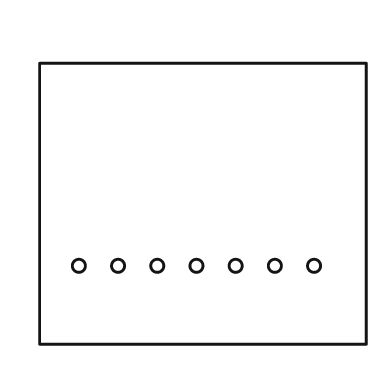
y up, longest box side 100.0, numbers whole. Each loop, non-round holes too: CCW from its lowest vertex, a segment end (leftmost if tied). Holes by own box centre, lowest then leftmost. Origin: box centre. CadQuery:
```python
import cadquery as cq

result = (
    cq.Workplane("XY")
    .moveTo(-50.0, -43.0)
    .lineTo(50.0, -43.0)
    .lineTo(50.0, 43.0)
    .lineTo(-50.0, 43.0)
    .close()
    .moveTo(-38.0, -19.0)
    .circle(2.0)
    .moveTo(-26.0, -19.0)
    .circle(2.0)
    .moveTo(-14.0, -19.0)
    .circle(2.0)
    .moveTo(-2.0, -19.0)
    .circle(2.0)
    .moveTo(10.0, -19.0)
    .circle(2.0)
    .moveTo(22.0, -19.0)
    .circle(2.0)
    .moveTo(34.0, -19.0)
    .circle(2.0)
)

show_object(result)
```